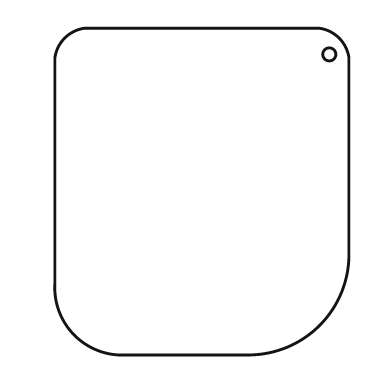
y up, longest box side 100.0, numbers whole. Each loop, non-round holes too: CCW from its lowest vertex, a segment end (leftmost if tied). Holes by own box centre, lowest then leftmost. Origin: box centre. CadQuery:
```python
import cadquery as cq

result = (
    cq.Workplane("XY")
    .moveTo(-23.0, -50.0)
    .lineTo(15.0, -50.0)
    .threePointArc((36.0, -41.0), (45.0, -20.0))
    .lineTo(45.0, 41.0)
    .threePointArc((42.0, 47.0), (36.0, 50.0))
    .lineTo(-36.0, 50.0)
    .threePointArc((-42.0, 47.0), (-45.0, 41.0))
    .lineTo(-45.0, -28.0)
    .threePointArc((-39.0, -44.0), (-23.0, -50.0))
    .close()
    .moveTo(39.0, 42.0)
    .circle(2.0)
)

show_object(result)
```